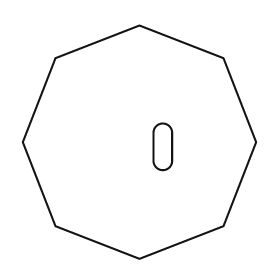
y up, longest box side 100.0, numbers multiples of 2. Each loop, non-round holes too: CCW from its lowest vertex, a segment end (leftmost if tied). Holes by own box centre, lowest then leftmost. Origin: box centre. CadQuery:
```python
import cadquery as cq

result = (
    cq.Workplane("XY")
    .moveTo(0.0, -50.0)
    .lineTo(36.0, -36.0)
    .lineTo(50.0, 0.0)
    .lineTo(36.0, 36.0)
    .lineTo(0.0, 50.0)
    .lineTo(-36.0, 36.0)
    .lineTo(-50.0, 0.0)
    .lineTo(-36.0, -36.0)
    .close()
    .moveTo(6.0, -8.0)
    .threePointArc((10.0, -12.0), (14.0, -8.0))
    .lineTo(14.0, 4.0)
    .threePointArc((10.0, 8.0), (6.0, 4.0))
    .close()
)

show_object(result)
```